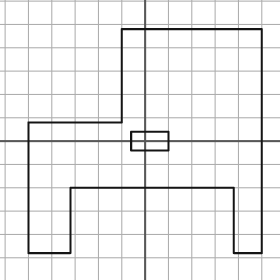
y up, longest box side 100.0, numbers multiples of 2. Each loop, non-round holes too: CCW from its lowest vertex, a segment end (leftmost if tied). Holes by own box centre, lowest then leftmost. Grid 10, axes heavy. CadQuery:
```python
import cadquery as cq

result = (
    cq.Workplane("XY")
    .moveTo(-50.0, -48.0)
    .lineTo(-32.0, -48.0)
    .lineTo(-32.0, -20.0)
    .lineTo(38.0, -20.0)
    .lineTo(38.0, -48.0)
    .lineTo(50.0, -48.0)
    .lineTo(50.0, 48.0)
    .lineTo(-10.0, 48.0)
    .lineTo(-10.0, 8.0)
    .lineTo(-50.0, 8.0)
    .close()
    .moveTo(-6.0, -4.0)
    .lineTo(10.0, -4.0)
    .lineTo(10.0, 4.0)
    .lineTo(-6.0, 4.0)
    .close()
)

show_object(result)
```